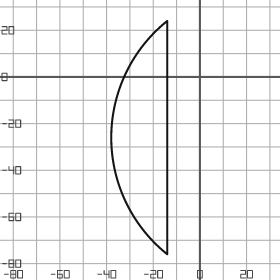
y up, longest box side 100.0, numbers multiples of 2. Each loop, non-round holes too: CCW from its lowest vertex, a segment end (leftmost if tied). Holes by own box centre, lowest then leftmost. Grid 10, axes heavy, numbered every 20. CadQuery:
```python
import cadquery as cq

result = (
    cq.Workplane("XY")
    .moveTo(-14.0, -76.0)
    .lineTo(-14.0, 24.0)
    .threePointArc((-38.0, -26.0), (-14.0, -76.0))
    .close()
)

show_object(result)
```